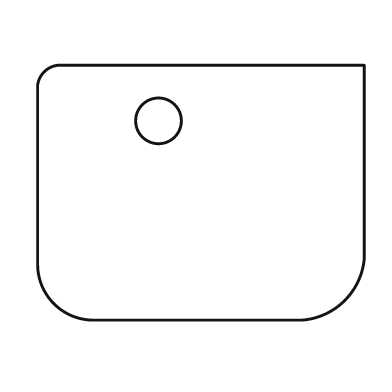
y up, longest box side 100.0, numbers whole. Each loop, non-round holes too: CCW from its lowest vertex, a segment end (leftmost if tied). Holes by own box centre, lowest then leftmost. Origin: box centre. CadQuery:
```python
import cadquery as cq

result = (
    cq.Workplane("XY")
    .moveTo(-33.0, -39.0)
    .lineTo(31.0, -39.0)
    .threePointArc((44.0, -33.0), (50.0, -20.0))
    .lineTo(50.0, 39.0)
    .lineTo(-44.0, 39.0)
    .threePointArc((-48.0, 37.0), (-50.0, 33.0))
    .lineTo(-50.0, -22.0)
    .threePointArc((-45.0, -34.0), (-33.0, -39.0))
    .close()
    .moveTo(-13.0, 22.0)
    .circle(7.0)
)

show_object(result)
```